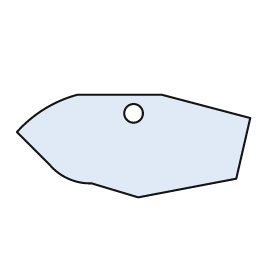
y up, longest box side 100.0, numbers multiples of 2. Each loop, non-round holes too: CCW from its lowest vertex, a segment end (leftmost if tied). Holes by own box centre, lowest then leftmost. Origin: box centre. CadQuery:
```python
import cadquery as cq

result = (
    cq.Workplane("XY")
    .moveTo(2.0, -22.0)
    .lineTo(44.0, -14.0)
    .lineTo(50.0, 12.0)
    .lineTo(12.0, 22.0)
    .lineTo(-24.0, 22.0)
    .threePointArc((-38.0, 16.0), (-50.0, 6.0))
    .lineTo(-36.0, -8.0)
    .threePointArc((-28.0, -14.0), (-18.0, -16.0))
    .close()
    .moveTo(0.0, 14.0)
    .circle(4.0)
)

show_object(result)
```